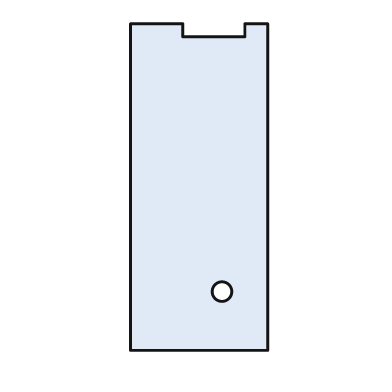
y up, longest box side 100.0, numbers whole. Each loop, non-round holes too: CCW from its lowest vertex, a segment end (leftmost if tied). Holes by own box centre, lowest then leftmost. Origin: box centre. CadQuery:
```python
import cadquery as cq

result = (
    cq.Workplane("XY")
    .moveTo(-21.0, -50.0)
    .lineTo(21.0, -50.0)
    .lineTo(21.0, 50.0)
    .lineTo(14.0, 50.0)
    .lineTo(14.0, 46.0)
    .lineTo(-5.0, 46.0)
    .lineTo(-5.0, 50.0)
    .lineTo(-21.0, 50.0)
    .close()
    .moveTo(7.0, -32.0)
    .circle(3.0)
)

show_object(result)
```